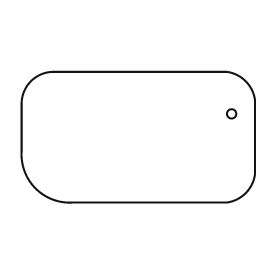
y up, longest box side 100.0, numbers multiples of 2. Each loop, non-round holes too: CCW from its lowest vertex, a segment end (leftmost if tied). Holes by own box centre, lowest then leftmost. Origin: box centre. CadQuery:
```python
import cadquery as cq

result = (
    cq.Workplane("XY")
    .moveTo(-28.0, -28.0)
    .lineTo(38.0, -28.0)
    .threePointArc((46.0, -24.0), (50.0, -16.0))
    .lineTo(50.0, 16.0)
    .threePointArc((46.0, 24.0), (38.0, 28.0))
    .lineTo(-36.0, 28.0)
    .threePointArc((-46.0, 24.0), (-50.0, 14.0))
    .lineTo(-50.0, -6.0)
    .threePointArc((-44.0, -22.0), (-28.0, -28.0))
    .close()
    .moveTo(40.0, 10.0)
    .circle(2.0)
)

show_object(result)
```